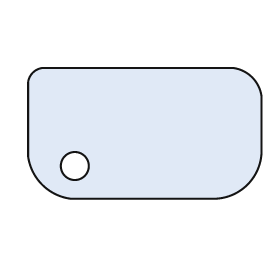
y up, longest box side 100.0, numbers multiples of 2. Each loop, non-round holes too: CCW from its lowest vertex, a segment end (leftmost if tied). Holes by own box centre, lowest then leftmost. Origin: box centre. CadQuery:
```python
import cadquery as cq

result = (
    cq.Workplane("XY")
    .moveTo(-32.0, -28.0)
    .lineTo(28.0, -28.0)
    .threePointArc((44.0, -22.0), (50.0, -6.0))
    .lineTo(50.0, 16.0)
    .threePointArc((46.0, 24.0), (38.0, 28.0))
    .lineTo(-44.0, 28.0)
    .threePointArc((-48.0, 26.0), (-50.0, 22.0))
    .lineTo(-50.0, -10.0)
    .threePointArc((-44.0, -22.0), (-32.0, -28.0))
    .close()
    .moveTo(-30.0, -14.0)
    .circle(6.0)
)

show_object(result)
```